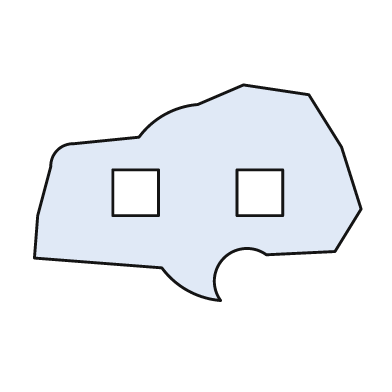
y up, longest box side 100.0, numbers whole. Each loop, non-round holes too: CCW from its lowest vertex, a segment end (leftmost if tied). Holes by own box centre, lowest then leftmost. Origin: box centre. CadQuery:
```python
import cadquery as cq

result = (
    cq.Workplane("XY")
    .moveTo(7.0, -33.0)
    .threePointArc((8.0, -20.0), (21.0, -19.0))
    .lineTo(42.0, -18.0)
    .lineTo(50.0, -5.0)
    .lineTo(44.0, 14.0)
    .lineTo(34.0, 30.0)
    .lineTo(14.0, 33.0)
    .lineTo(0.0, 27.0)
    .threePointArc((-10.0, 24.0), (-18.0, 17.0))
    .lineTo(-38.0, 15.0)
    .threePointArc((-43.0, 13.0), (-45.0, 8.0))
    .lineTo(-49.0, -7.0)
    .lineTo(-50.0, -20.0)
    .lineTo(-11.0, -23.0)
    .threePointArc((-3.0, -30.0), (7.0, -33.0))
    .close()
    .moveTo(-26.0, -7.0)
    .lineTo(-12.0, -7.0)
    .lineTo(-12.0, 7.0)
    .lineTo(-26.0, 7.0)
    .close()
    .moveTo(12.0, -7.0)
    .lineTo(26.0, -7.0)
    .lineTo(26.0, 7.0)
    .lineTo(12.0, 7.0)
    .close()
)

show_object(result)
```